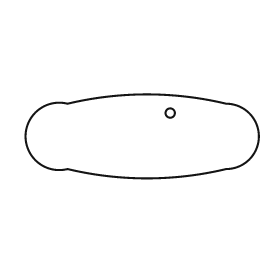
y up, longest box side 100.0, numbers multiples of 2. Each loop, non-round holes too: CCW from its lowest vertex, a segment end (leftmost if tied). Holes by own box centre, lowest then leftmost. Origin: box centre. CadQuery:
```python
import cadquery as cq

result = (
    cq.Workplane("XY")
    .moveTo(-32.0, -14.0)
    .threePointArc((2.0, -18.0), (36.0, -14.0))
    .threePointArc((50.0, 0.0), (36.0, 14.0))
    .threePointArc((2.0, 18.0), (-32.0, 14.0))
    .threePointArc((-50.0, 0.0), (-32.0, -14.0))
    .close()
    .moveTo(12.0, 10.0)
    .circle(2.0)
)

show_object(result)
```